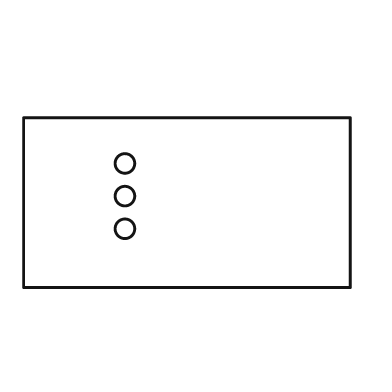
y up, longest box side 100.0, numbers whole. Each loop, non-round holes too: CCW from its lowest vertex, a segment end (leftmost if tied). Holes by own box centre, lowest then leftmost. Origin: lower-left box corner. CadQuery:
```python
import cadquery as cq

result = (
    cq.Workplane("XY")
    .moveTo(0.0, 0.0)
    .lineTo(100.0, 0.0)
    .lineTo(100.0, 52.0)
    .lineTo(0.0, 52.0)
    .close()
    .moveTo(31.0, 18.0)
    .circle(3.0)
    .moveTo(31.0, 28.0)
    .circle(3.0)
    .moveTo(31.0, 38.0)
    .circle(3.0)
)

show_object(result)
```